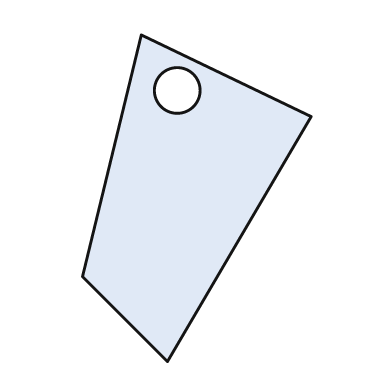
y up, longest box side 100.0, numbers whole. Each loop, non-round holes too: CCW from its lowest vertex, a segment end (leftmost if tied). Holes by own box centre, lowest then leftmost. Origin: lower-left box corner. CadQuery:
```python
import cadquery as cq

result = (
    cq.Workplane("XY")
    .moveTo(26.0, 0.0)
    .lineTo(70.0, 75.0)
    .lineTo(18.0, 100.0)
    .lineTo(0.0, 26.0)
    .close()
    .moveTo(29.0, 83.0)
    .circle(7.0)
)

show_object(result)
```